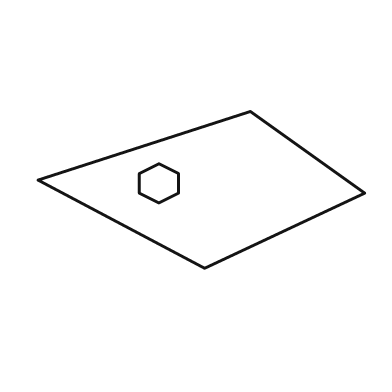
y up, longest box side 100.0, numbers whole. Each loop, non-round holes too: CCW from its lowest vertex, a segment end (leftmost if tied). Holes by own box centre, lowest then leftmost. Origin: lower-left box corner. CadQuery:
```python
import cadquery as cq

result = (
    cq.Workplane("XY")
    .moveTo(51.0, 0.0)
    .lineTo(100.0, 23.0)
    .lineTo(65.0, 48.0)
    .lineTo(0.0, 27.0)
    .close()
    .moveTo(37.0, 20.0)
    .lineTo(43.0, 23.0)
    .lineTo(43.0, 29.0)
    .lineTo(37.0, 32.0)
    .lineTo(31.0, 29.0)
    .lineTo(31.0, 23.0)
    .close()
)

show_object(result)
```